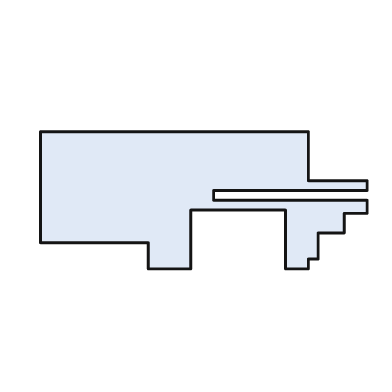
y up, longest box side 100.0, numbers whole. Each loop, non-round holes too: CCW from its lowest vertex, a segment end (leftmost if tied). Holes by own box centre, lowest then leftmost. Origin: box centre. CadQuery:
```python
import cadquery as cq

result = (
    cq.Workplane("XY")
    .moveTo(-17.0, -21.0)
    .lineTo(-4.0, -21.0)
    .lineTo(-4.0, -3.0)
    .lineTo(25.0, -3.0)
    .lineTo(25.0, -21.0)
    .lineTo(32.0, -21.0)
    .lineTo(32.0, -18.0)
    .lineTo(35.0, -18.0)
    .lineTo(35.0, -10.0)
    .lineTo(43.0, -10.0)
    .lineTo(43.0, -4.0)
    .lineTo(50.0, -4.0)
    .lineTo(50.0, 0.0)
    .lineTo(3.0, 0.0)
    .lineTo(3.0, 3.0)
    .lineTo(50.0, 3.0)
    .lineTo(50.0, 6.0)
    .lineTo(32.0, 6.0)
    .lineTo(32.0, 21.0)
    .lineTo(-50.0, 21.0)
    .lineTo(-50.0, -13.0)
    .lineTo(-17.0, -13.0)
    .close()
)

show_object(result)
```